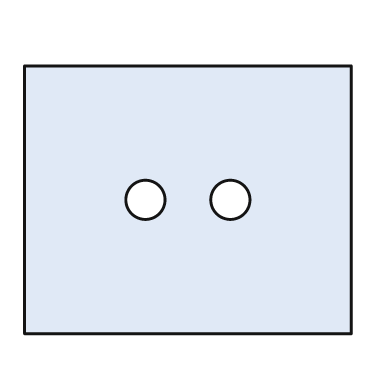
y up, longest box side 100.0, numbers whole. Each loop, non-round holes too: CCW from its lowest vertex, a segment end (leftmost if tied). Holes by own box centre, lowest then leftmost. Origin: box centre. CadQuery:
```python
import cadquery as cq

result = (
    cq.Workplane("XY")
    .moveTo(-50.0, -41.0)
    .lineTo(50.0, -41.0)
    .lineTo(50.0, 41.0)
    .lineTo(-50.0, 41.0)
    .close()
    .moveTo(-13.0, 0.0)
    .circle(6.0)
    .moveTo(13.0, 0.0)
    .circle(6.0)
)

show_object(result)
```